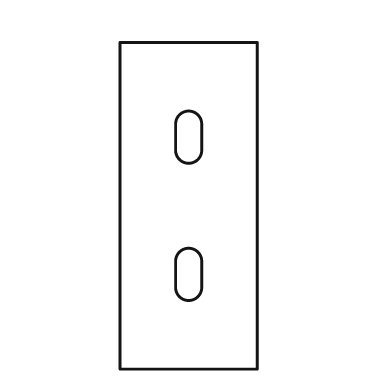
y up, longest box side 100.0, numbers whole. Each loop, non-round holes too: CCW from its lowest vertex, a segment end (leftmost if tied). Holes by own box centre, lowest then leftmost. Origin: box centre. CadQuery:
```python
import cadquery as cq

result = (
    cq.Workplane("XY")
    .moveTo(-21.0, -50.0)
    .lineTo(21.0, -50.0)
    .lineTo(21.0, 50.0)
    .lineTo(-21.0, 50.0)
    .close()
    .moveTo(-4.0, -25.0)
    .threePointArc((0.0, -29.0), (4.0, -25.0))
    .lineTo(4.0, -17.0)
    .threePointArc((0.0, -13.0), (-4.0, -17.0))
    .close()
    .moveTo(-4.0, 17.0)
    .threePointArc((0.0, 13.0), (4.0, 17.0))
    .lineTo(4.0, 25.0)
    .threePointArc((0.0, 29.0), (-4.0, 25.0))
    .close()
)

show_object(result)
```